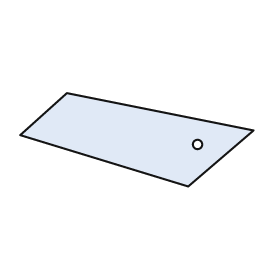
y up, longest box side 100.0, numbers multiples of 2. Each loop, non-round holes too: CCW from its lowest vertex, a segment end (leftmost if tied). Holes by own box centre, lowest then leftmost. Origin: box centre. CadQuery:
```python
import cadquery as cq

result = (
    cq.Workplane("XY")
    .moveTo(22.0, -20.0)
    .lineTo(50.0, 4.0)
    .lineTo(-30.0, 20.0)
    .lineTo(-50.0, 2.0)
    .close()
    .moveTo(26.0, -2.0)
    .circle(2.0)
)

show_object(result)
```